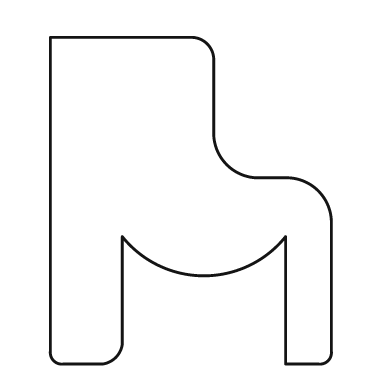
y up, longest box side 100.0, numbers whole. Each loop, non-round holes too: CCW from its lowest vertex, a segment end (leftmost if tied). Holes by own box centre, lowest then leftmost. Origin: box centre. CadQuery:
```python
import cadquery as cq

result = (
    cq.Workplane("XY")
    .moveTo(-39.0, -50.0)
    .lineTo(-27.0, -50.0)
    .threePointArc((-23.0, -48.0), (-21.0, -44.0))
    .lineTo(-21.0, -11.0)
    .threePointArc((4.0, -23.0), (29.0, -11.0))
    .lineTo(29.0, -50.0)
    .lineTo(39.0, -50.0)
    .threePointArc((42.0, -49.0), (43.0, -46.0))
    .lineTo(43.0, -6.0)
    .threePointArc((39.0, 3.0), (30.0, 7.0))
    .lineTo(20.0, 7.0)
    .threePointArc((11.0, 11.0), (7.0, 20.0))
    .lineTo(7.0, 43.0)
    .threePointArc((5.0, 48.0), (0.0, 50.0))
    .lineTo(-43.0, 50.0)
    .lineTo(-43.0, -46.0)
    .threePointArc((-42.0, -49.0), (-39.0, -50.0))
    .close()
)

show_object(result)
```